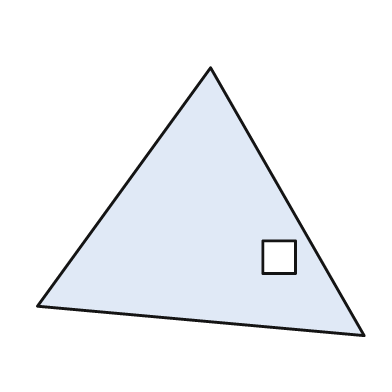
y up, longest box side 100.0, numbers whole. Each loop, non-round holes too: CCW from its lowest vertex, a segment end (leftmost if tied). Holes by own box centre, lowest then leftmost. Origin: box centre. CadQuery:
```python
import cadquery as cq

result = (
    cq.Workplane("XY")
    .moveTo(50.0, -41.0)
    .lineTo(3.0, 41.0)
    .lineTo(-50.0, -32.0)
    .close()
    .moveTo(19.0, -22.0)
    .lineTo(29.0, -22.0)
    .lineTo(29.0, -12.0)
    .lineTo(19.0, -12.0)
    .close()
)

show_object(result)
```